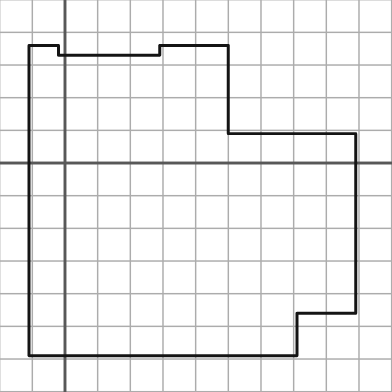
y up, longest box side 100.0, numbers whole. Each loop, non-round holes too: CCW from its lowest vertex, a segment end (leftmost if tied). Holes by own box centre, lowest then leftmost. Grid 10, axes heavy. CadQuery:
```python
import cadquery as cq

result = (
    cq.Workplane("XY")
    .moveTo(-11.0, -59.0)
    .lineTo(71.0, -59.0)
    .lineTo(71.0, -46.0)
    .lineTo(89.0, -46.0)
    .lineTo(89.0, 9.0)
    .lineTo(50.0, 9.0)
    .lineTo(50.0, 36.0)
    .lineTo(29.0, 36.0)
    .lineTo(29.0, 33.0)
    .lineTo(-2.0, 33.0)
    .lineTo(-2.0, 36.0)
    .lineTo(-11.0, 36.0)
    .close()
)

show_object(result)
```